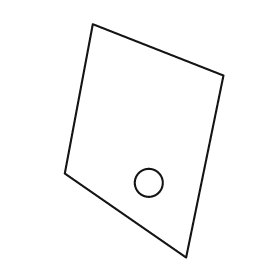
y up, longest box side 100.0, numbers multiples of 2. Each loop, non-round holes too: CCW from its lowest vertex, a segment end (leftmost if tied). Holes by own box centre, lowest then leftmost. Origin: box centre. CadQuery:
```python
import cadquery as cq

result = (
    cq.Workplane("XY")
    .moveTo(18.0, -50.0)
    .lineTo(34.0, 28.0)
    .lineTo(-22.0, 50.0)
    .lineTo(-34.0, -14.0)
    .close()
    .moveTo(2.0, -18.0)
    .circle(6.0)
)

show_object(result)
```